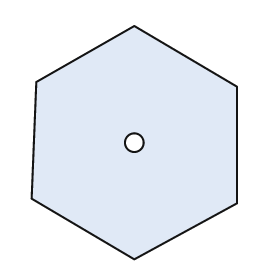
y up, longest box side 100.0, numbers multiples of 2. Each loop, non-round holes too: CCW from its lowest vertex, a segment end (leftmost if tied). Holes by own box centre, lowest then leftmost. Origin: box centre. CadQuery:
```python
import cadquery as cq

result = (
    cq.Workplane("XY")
    .moveTo(0.0, -50.0)
    .lineTo(44.0, -26.0)
    .lineTo(44.0, 24.0)
    .lineTo(0.0, 50.0)
    .lineTo(-42.0, 26.0)
    .lineTo(-44.0, -24.0)
    .close()
    .moveTo(0.0, 0.0)
    .circle(4.0)
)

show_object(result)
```